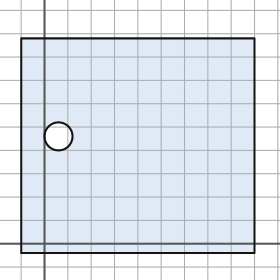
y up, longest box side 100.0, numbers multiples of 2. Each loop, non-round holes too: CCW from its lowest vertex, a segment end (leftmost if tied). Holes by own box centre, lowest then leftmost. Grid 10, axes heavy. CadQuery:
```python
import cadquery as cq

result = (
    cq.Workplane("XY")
    .moveTo(-10.0, -4.0)
    .lineTo(90.0, -4.0)
    .lineTo(90.0, 88.0)
    .lineTo(-10.0, 88.0)
    .close()
    .moveTo(6.0, 46.0)
    .circle(6.0)
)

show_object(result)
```